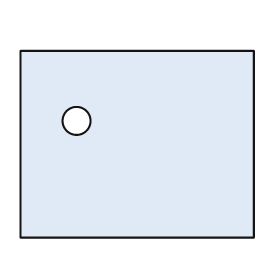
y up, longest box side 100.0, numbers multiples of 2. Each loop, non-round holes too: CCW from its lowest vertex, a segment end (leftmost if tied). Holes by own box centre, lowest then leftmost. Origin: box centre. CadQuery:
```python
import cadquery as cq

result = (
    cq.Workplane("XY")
    .moveTo(-50.0, -40.0)
    .lineTo(50.0, -40.0)
    .lineTo(50.0, 40.0)
    .lineTo(-50.0, 40.0)
    .close()
    .moveTo(-26.0, 10.0)
    .circle(6.0)
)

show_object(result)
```